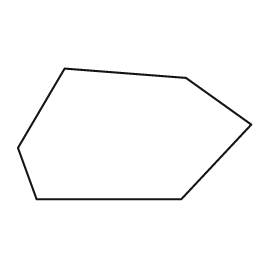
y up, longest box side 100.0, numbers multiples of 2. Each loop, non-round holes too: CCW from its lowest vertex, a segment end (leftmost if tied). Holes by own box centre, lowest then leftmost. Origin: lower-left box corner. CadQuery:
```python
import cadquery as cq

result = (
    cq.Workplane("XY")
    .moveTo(8.0, 0.0)
    .lineTo(70.0, 0.0)
    .lineTo(100.0, 32.0)
    .lineTo(72.0, 52.0)
    .lineTo(20.0, 56.0)
    .lineTo(0.0, 22.0)
    .close()
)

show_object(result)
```